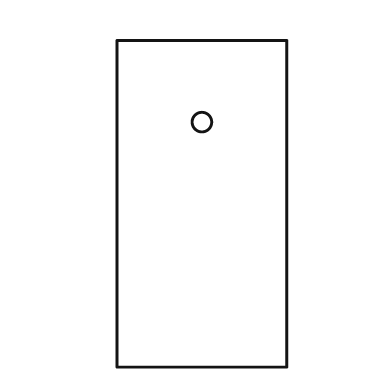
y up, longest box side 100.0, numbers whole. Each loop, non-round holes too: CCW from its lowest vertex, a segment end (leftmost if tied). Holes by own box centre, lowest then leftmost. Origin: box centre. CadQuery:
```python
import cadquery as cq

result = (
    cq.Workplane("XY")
    .moveTo(-26.0, -50.0)
    .lineTo(26.0, -50.0)
    .lineTo(26.0, 50.0)
    .lineTo(-26.0, 50.0)
    .close()
    .moveTo(0.0, 25.0)
    .circle(3.0)
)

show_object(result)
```